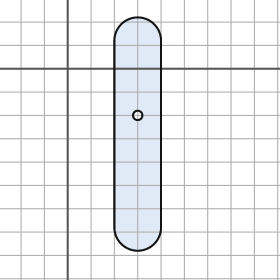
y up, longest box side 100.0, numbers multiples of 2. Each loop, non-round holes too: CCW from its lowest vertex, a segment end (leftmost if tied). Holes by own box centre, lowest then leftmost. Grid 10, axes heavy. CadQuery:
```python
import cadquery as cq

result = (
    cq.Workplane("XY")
    .moveTo(20.0, -68.0)
    .threePointArc((30.0, -78.0), (40.0, -68.0))
    .lineTo(40.0, 12.0)
    .threePointArc((30.0, 22.0), (20.0, 12.0))
    .close()
    .moveTo(30.0, -20.0)
    .circle(2.0)
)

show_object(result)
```